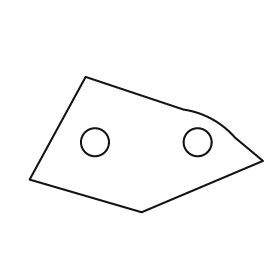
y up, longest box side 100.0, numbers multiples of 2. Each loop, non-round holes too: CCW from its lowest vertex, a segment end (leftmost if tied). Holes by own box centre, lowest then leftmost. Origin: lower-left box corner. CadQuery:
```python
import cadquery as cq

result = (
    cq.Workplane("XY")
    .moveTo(48.0, 0.0)
    .lineTo(100.0, 22.0)
    .lineTo(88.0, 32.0)
    .threePointArc((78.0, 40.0), (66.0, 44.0))
    .lineTo(24.0, 58.0)
    .lineTo(0.0, 14.0)
    .close()
    .moveTo(28.0, 30.0)
    .circle(6.0)
    .moveTo(72.0, 30.0)
    .circle(6.0)
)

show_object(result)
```